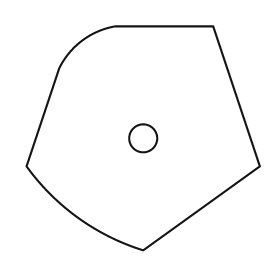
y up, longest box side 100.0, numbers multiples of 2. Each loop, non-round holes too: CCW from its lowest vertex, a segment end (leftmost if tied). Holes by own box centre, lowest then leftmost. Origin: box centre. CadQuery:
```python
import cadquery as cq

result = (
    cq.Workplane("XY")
    .moveTo(0.0, -48.0)
    .lineTo(50.0, -12.0)
    .lineTo(30.0, 48.0)
    .lineTo(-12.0, 48.0)
    .threePointArc((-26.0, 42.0), (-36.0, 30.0))
    .lineTo(-50.0, -12.0)
    .threePointArc((-28.0, -34.0), (0.0, -48.0))
    .close()
    .moveTo(0.0, 0.0)
    .circle(6.0)
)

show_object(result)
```